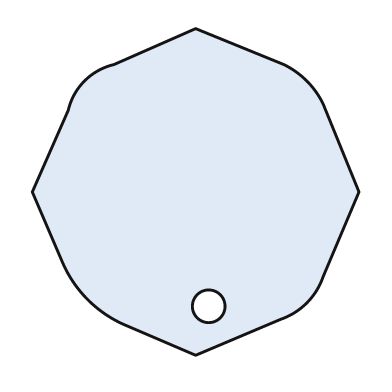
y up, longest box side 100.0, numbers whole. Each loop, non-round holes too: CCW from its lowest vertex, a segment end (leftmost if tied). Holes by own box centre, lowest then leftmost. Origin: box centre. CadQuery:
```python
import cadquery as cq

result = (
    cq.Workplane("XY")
    .moveTo(0.0, -50.0)
    .lineTo(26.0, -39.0)
    .threePointArc((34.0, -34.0), (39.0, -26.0))
    .lineTo(50.0, 0.0)
    .lineTo(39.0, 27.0)
    .threePointArc((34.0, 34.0), (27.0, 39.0))
    .lineTo(0.0, 50.0)
    .lineTo(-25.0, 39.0)
    .threePointArc((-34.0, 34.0), (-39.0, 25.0))
    .lineTo(-50.0, 0.0)
    .lineTo(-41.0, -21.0)
    .threePointArc((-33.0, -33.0), (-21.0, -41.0))
    .close()
    .moveTo(4.0, -35.0)
    .circle(5.0)
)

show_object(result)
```